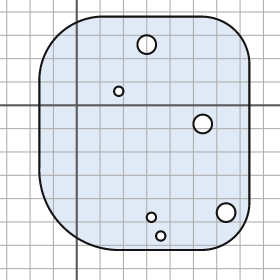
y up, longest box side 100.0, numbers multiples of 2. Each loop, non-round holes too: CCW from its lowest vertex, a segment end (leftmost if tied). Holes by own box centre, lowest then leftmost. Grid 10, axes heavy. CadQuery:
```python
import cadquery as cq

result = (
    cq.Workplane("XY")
    .moveTo(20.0, -62.0)
    .lineTo(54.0, -62.0)
    .threePointArc((68.0, -56.0), (74.0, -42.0))
    .lineTo(74.0, 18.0)
    .threePointArc((68.0, 32.0), (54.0, 38.0))
    .lineTo(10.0, 38.0)
    .threePointArc((-8.0, 30.0), (-16.0, 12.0))
    .lineTo(-16.0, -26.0)
    .threePointArc((-6.0, -52.0), (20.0, -62.0))
    .close()
    .moveTo(36.0, -56.0)
    .circle(2.0)
    .moveTo(32.0, -48.0)
    .circle(2.0)
    .moveTo(64.0, -46.0)
    .circle(4.0)
    .moveTo(54.0, -8.0)
    .circle(4.0)
    .moveTo(18.0, 6.0)
    .circle(2.0)
    .moveTo(30.0, 26.0)
    .circle(4.0)
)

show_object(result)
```